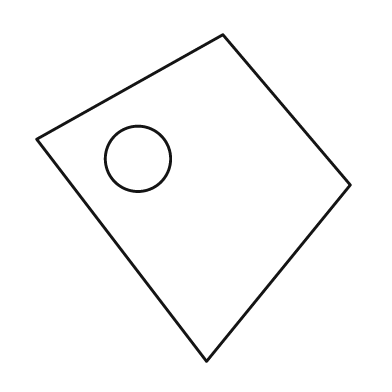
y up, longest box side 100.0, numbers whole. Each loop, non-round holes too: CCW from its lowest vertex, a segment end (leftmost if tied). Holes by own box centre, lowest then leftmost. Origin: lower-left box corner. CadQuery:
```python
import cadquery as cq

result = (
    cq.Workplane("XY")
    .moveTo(52.0, 0.0)
    .lineTo(96.0, 54.0)
    .lineTo(57.0, 100.0)
    .lineTo(0.0, 68.0)
    .close()
    .moveTo(31.0, 62.0)
    .circle(10.0)
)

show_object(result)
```